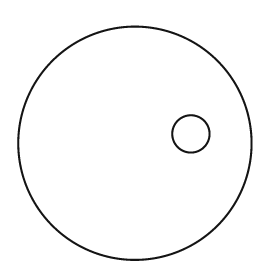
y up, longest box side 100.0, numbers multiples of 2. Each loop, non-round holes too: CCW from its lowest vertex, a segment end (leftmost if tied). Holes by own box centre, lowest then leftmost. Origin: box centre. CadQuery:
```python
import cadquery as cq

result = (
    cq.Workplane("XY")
    .moveTo(0.0, 0.0)
    .circle(50.0)
    .moveTo(24.0, 4.0)
    .circle(8.0)
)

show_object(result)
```